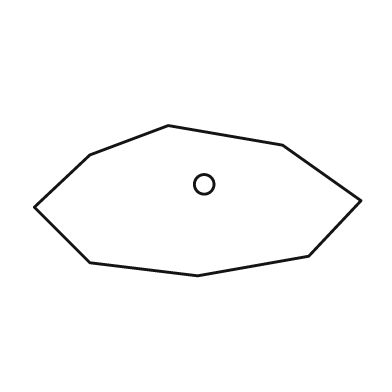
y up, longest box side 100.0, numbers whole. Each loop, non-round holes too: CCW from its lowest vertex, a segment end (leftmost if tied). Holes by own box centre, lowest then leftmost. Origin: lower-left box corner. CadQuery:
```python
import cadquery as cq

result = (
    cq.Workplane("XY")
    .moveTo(50.0, 0.0)
    .lineTo(84.0, 6.0)
    .lineTo(100.0, 23.0)
    .lineTo(76.0, 40.0)
    .lineTo(41.0, 46.0)
    .lineTo(17.0, 37.0)
    .lineTo(0.0, 21.0)
    .lineTo(17.0, 4.0)
    .close()
    .moveTo(52.0, 28.0)
    .circle(3.0)
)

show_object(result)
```